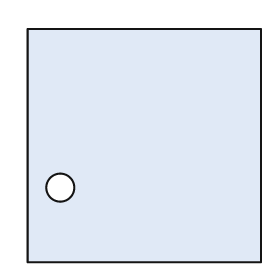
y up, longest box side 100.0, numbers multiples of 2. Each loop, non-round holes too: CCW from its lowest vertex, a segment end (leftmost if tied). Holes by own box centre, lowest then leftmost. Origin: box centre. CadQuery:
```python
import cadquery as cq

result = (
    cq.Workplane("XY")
    .moveTo(-50.0, -50.0)
    .lineTo(50.0, -50.0)
    .lineTo(50.0, 50.0)
    .lineTo(-50.0, 50.0)
    .close()
    .moveTo(-36.0, -18.0)
    .circle(6.0)
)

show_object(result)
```